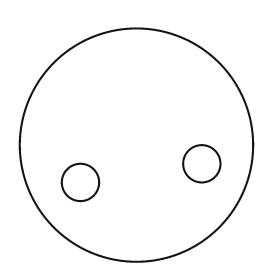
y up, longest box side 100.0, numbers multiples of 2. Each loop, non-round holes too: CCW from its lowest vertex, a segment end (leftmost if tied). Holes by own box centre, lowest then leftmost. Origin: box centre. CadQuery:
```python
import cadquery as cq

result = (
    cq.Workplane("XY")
    .moveTo(0.0, 0.0)
    .circle(50.0)
    .moveTo(-24.0, -16.0)
    .circle(8.0)
    .moveTo(28.0, -8.0)
    .circle(8.0)
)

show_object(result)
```